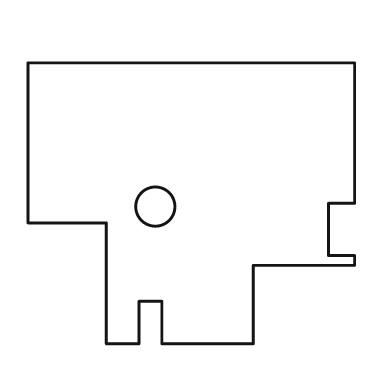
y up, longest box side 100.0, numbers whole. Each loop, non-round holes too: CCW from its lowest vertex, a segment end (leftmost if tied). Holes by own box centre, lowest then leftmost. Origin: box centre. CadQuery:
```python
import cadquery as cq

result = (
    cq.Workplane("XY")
    .moveTo(-26.0, -43.0)
    .lineTo(-16.0, -43.0)
    .lineTo(-16.0, -30.0)
    .lineTo(-9.0, -30.0)
    .lineTo(-9.0, -43.0)
    .lineTo(19.0, -43.0)
    .lineTo(19.0, -19.0)
    .lineTo(50.0, -19.0)
    .lineTo(50.0, -16.0)
    .lineTo(42.0, -16.0)
    .lineTo(42.0, 0.0)
    .lineTo(50.0, 0.0)
    .lineTo(50.0, 43.0)
    .lineTo(-50.0, 43.0)
    .lineTo(-50.0, -6.0)
    .lineTo(-26.0, -6.0)
    .close()
    .moveTo(-11.0, -1.0)
    .circle(6.0)
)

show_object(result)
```